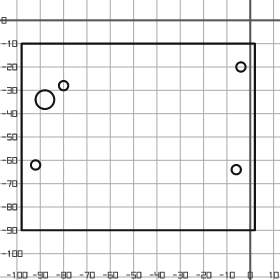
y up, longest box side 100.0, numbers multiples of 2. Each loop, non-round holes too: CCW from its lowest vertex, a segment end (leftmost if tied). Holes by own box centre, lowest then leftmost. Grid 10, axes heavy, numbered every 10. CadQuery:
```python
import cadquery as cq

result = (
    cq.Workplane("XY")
    .moveTo(-98.0, -90.0)
    .lineTo(2.0, -90.0)
    .lineTo(2.0, -10.0)
    .lineTo(-98.0, -10.0)
    .close()
    .moveTo(-6.0, -64.0)
    .circle(2.0)
    .moveTo(-92.0, -62.0)
    .circle(2.0)
    .moveTo(-88.0, -34.0)
    .circle(4.0)
    .moveTo(-80.0, -28.0)
    .circle(2.0)
    .moveTo(-4.0, -20.0)
    .circle(2.0)
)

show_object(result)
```